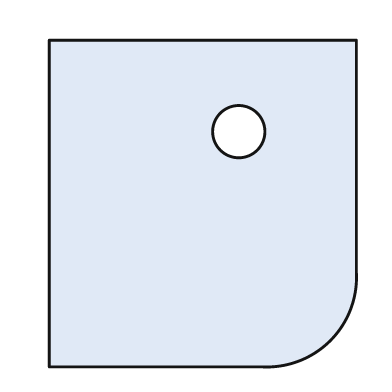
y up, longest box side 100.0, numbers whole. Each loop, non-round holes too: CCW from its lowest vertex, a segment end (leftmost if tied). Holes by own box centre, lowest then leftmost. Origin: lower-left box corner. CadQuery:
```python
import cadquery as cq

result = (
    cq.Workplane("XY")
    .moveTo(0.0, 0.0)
    .lineTo(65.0, 0.0)
    .threePointArc((86.0, 8.0), (94.0, 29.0))
    .lineTo(94.0, 100.0)
    .lineTo(0.0, 100.0)
    .close()
    .moveTo(58.0, 72.0)
    .circle(8.0)
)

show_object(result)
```